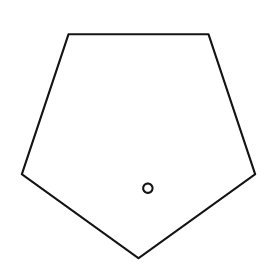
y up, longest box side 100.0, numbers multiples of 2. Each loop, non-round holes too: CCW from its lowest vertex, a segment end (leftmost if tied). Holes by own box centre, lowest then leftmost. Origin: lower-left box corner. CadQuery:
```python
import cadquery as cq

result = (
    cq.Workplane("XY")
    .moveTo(50.0, 0.0)
    .lineTo(100.0, 36.0)
    .lineTo(80.0, 96.0)
    .lineTo(20.0, 96.0)
    .lineTo(0.0, 36.0)
    .close()
    .moveTo(54.0, 30.0)
    .circle(2.0)
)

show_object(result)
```